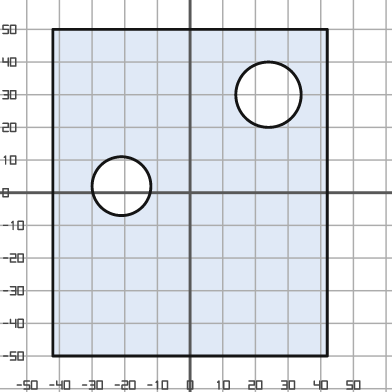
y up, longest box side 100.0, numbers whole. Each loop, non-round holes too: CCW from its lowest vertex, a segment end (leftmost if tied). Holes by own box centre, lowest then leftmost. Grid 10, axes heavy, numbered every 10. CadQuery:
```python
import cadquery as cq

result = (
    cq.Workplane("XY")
    .moveTo(-42.0, -50.0)
    .lineTo(42.0, -50.0)
    .lineTo(42.0, 50.0)
    .lineTo(-42.0, 50.0)
    .close()
    .moveTo(-21.0, 2.0)
    .circle(9.0)
    .moveTo(24.0, 30.0)
    .circle(10.0)
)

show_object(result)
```